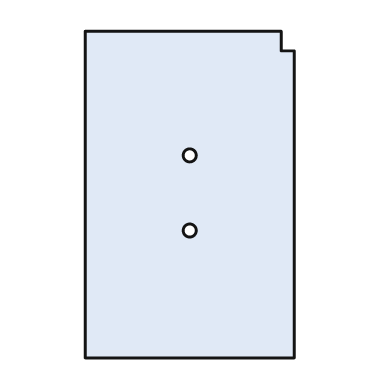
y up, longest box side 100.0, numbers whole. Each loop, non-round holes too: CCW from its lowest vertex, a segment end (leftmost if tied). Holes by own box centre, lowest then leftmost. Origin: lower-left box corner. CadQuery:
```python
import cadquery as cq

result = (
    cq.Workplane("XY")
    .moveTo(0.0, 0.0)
    .lineTo(64.0, 0.0)
    .lineTo(64.0, 94.0)
    .lineTo(60.0, 94.0)
    .lineTo(60.0, 100.0)
    .lineTo(0.0, 100.0)
    .close()
    .moveTo(32.0, 39.0)
    .circle(2.0)
    .moveTo(32.0, 62.0)
    .circle(2.0)
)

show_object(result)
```